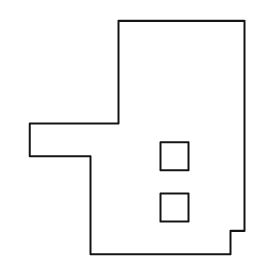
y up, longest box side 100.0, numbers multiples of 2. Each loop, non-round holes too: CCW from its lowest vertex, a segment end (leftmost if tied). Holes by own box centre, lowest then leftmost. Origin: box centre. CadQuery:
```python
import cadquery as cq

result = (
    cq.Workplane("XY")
    .moveTo(-20.0, -50.0)
    .lineTo(40.0, -50.0)
    .lineTo(40.0, -40.0)
    .lineTo(46.0, -40.0)
    .lineTo(46.0, 50.0)
    .lineTo(-8.0, 50.0)
    .lineTo(-8.0, 6.0)
    .lineTo(-46.0, 6.0)
    .lineTo(-46.0, -8.0)
    .lineTo(-20.0, -8.0)
    .close()
    .moveTo(10.0, -36.0)
    .lineTo(22.0, -36.0)
    .lineTo(22.0, -24.0)
    .lineTo(10.0, -24.0)
    .close()
    .moveTo(10.0, -14.0)
    .lineTo(22.0, -14.0)
    .lineTo(22.0, -2.0)
    .lineTo(10.0, -2.0)
    .close()
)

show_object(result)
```